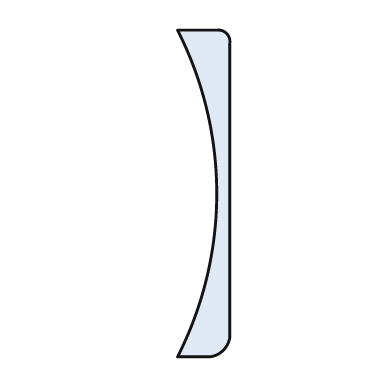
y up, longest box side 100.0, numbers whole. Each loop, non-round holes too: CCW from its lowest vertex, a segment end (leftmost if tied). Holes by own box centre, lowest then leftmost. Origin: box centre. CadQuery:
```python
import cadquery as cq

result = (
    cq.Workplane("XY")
    .moveTo(-8.0, -50.0)
    .lineTo(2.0, -50.0)
    .threePointArc((6.0, -48.0), (8.0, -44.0))
    .lineTo(8.0, 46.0)
    .threePointArc((7.0, 49.0), (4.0, 50.0))
    .lineTo(-8.0, 50.0)
    .threePointArc((4.0, 0.0), (-8.0, -50.0))
    .close()
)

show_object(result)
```